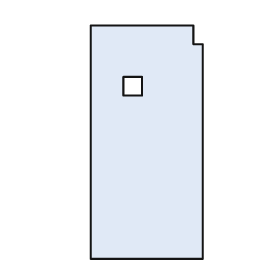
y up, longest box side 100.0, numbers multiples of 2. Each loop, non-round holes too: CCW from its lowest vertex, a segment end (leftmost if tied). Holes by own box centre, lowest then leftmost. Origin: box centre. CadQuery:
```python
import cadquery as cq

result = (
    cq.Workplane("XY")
    .moveTo(-24.0, -50.0)
    .lineTo(24.0, -50.0)
    .lineTo(24.0, 42.0)
    .lineTo(20.0, 42.0)
    .lineTo(20.0, 50.0)
    .lineTo(-24.0, 50.0)
    .close()
    .moveTo(-10.0, 20.0)
    .lineTo(-2.0, 20.0)
    .lineTo(-2.0, 28.0)
    .lineTo(-10.0, 28.0)
    .close()
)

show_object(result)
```